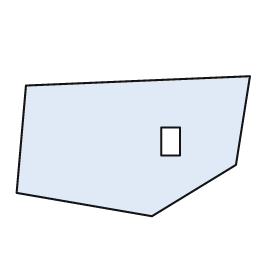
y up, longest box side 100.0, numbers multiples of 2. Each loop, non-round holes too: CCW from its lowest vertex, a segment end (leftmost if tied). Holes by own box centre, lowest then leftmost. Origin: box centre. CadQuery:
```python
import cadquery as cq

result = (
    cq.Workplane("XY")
    .moveTo(8.0, -30.0)
    .lineTo(44.0, -8.0)
    .lineTo(50.0, 30.0)
    .lineTo(-46.0, 26.0)
    .lineTo(-50.0, -20.0)
    .close()
    .moveTo(12.0, -4.0)
    .lineTo(20.0, -4.0)
    .lineTo(20.0, 8.0)
    .lineTo(12.0, 8.0)
    .close()
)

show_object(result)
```